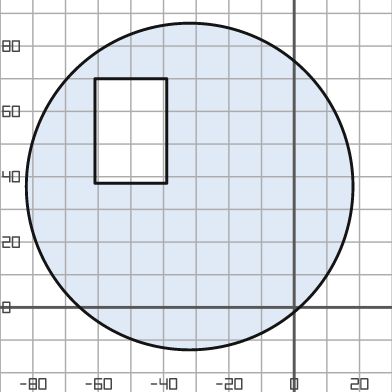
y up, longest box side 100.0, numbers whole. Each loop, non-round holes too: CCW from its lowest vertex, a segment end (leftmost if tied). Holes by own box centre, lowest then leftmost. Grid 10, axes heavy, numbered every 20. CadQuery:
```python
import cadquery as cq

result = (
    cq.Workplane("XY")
    .moveTo(-32.0, 37.0)
    .circle(50.0)
    .moveTo(-61.0, 38.0)
    .lineTo(-39.0, 38.0)
    .lineTo(-39.0, 70.0)
    .lineTo(-61.0, 70.0)
    .close()
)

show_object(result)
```